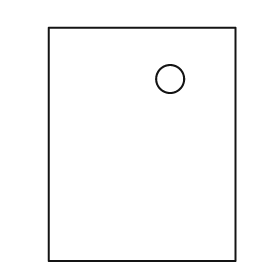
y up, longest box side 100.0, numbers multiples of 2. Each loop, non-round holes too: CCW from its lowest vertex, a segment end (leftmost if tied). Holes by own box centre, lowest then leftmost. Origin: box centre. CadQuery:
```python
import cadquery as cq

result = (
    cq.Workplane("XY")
    .moveTo(-40.0, -50.0)
    .lineTo(40.0, -50.0)
    .lineTo(40.0, 50.0)
    .lineTo(-40.0, 50.0)
    .close()
    .moveTo(12.0, 28.0)
    .circle(6.0)
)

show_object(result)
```